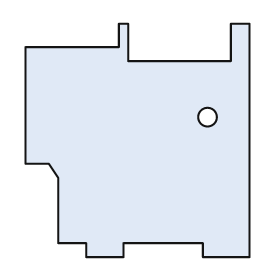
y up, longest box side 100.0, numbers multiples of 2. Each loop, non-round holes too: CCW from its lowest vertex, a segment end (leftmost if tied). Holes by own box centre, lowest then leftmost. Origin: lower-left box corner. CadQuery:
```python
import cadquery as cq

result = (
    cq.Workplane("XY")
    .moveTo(26.0, 0.0)
    .lineTo(42.0, 0.0)
    .lineTo(42.0, 6.0)
    .lineTo(76.0, 6.0)
    .lineTo(76.0, 0.0)
    .lineTo(96.0, 0.0)
    .lineTo(96.0, 100.0)
    .lineTo(88.0, 100.0)
    .lineTo(88.0, 84.0)
    .lineTo(44.0, 84.0)
    .lineTo(44.0, 100.0)
    .lineTo(40.0, 100.0)
    .lineTo(40.0, 90.0)
    .lineTo(0.0, 90.0)
    .lineTo(0.0, 40.0)
    .lineTo(10.0, 40.0)
    .lineTo(14.0, 34.0)
    .lineTo(14.0, 6.0)
    .lineTo(26.0, 6.0)
    .close()
    .moveTo(78.0, 60.0)
    .circle(4.0)
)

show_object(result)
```